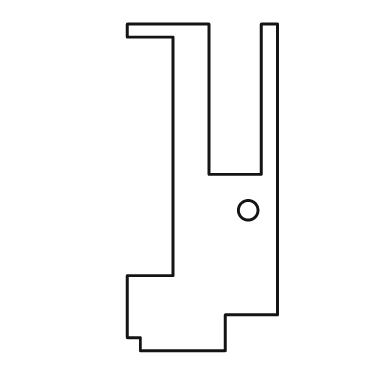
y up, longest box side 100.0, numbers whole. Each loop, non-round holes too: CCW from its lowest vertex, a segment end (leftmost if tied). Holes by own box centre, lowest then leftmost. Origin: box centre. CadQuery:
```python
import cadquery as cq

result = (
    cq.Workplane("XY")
    .moveTo(-19.0, -50.0)
    .lineTo(7.0, -50.0)
    .lineTo(7.0, -39.0)
    .lineTo(23.0, -39.0)
    .lineTo(23.0, 50.0)
    .lineTo(18.0, 50.0)
    .lineTo(18.0, 4.0)
    .lineTo(2.0, 4.0)
    .lineTo(2.0, 50.0)
    .lineTo(-23.0, 50.0)
    .lineTo(-23.0, 46.0)
    .lineTo(-9.0, 46.0)
    .lineTo(-9.0, -27.0)
    .lineTo(-23.0, -27.0)
    .lineTo(-23.0, -46.0)
    .lineTo(-19.0, -46.0)
    .close()
    .moveTo(14.0, -7.0)
    .circle(3.0)
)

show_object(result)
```